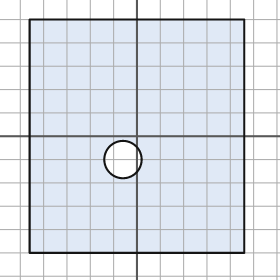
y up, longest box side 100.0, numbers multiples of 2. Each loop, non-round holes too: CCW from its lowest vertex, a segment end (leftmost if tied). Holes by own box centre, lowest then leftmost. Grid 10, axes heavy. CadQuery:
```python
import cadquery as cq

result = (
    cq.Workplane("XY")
    .moveTo(-46.0, -50.0)
    .lineTo(46.0, -50.0)
    .lineTo(46.0, 50.0)
    .lineTo(-46.0, 50.0)
    .close()
    .moveTo(-6.0, -10.0)
    .circle(8.0)
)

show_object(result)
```